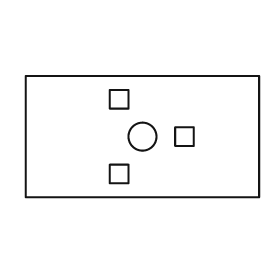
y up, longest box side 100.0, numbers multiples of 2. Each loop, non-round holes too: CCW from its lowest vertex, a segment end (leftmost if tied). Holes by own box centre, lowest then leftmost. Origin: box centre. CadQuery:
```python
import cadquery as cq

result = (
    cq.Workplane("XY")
    .moveTo(-50.0, -26.0)
    .lineTo(50.0, -26.0)
    .lineTo(50.0, 26.0)
    .lineTo(-50.0, 26.0)
    .close()
    .moveTo(-14.0, -20.0)
    .lineTo(-6.0, -20.0)
    .lineTo(-6.0, -12.0)
    .lineTo(-14.0, -12.0)
    .close()
    .moveTo(0.0, 0.0)
    .circle(6.0)
    .moveTo(14.0, -4.0)
    .lineTo(22.0, -4.0)
    .lineTo(22.0, 4.0)
    .lineTo(14.0, 4.0)
    .close()
    .moveTo(-14.0, 12.0)
    .lineTo(-6.0, 12.0)
    .lineTo(-6.0, 20.0)
    .lineTo(-14.0, 20.0)
    .close()
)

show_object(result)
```